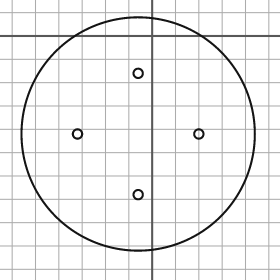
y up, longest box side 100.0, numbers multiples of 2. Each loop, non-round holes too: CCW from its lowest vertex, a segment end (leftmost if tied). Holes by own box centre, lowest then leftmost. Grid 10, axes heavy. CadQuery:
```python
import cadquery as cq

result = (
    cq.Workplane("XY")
    .moveTo(-6.0, -42.0)
    .circle(50.0)
    .moveTo(-6.0, -68.0)
    .circle(2.0)
    .moveTo(-32.0, -42.0)
    .circle(2.0)
    .moveTo(20.0, -42.0)
    .circle(2.0)
    .moveTo(-6.0, -16.0)
    .circle(2.0)
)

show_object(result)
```